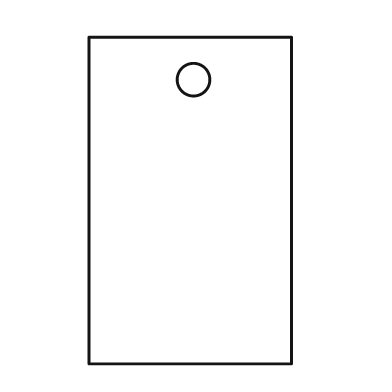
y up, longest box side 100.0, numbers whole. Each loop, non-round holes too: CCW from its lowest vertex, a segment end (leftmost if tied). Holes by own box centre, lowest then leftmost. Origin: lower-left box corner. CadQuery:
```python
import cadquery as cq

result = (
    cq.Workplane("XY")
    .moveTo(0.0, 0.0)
    .lineTo(62.0, 0.0)
    .lineTo(62.0, 100.0)
    .lineTo(0.0, 100.0)
    .close()
    .moveTo(32.0, 87.0)
    .circle(5.0)
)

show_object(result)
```